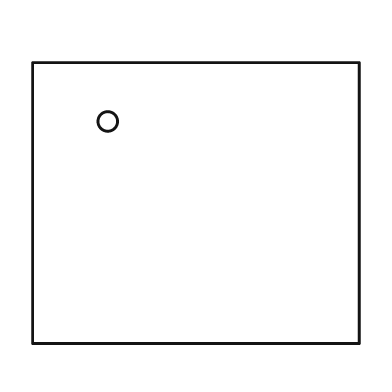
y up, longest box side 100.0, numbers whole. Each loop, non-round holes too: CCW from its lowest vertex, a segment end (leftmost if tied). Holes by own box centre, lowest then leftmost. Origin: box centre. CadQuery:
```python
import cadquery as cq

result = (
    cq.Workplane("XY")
    .moveTo(-50.0, -43.0)
    .lineTo(50.0, -43.0)
    .lineTo(50.0, 43.0)
    .lineTo(-50.0, 43.0)
    .close()
    .moveTo(-27.0, 25.0)
    .circle(3.0)
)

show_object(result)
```